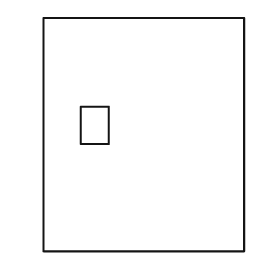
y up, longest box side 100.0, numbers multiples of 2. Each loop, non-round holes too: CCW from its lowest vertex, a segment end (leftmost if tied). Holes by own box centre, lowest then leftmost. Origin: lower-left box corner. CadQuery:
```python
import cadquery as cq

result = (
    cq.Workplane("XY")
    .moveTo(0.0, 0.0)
    .lineTo(86.0, 0.0)
    .lineTo(86.0, 100.0)
    .lineTo(0.0, 100.0)
    .close()
    .moveTo(16.0, 46.0)
    .lineTo(28.0, 46.0)
    .lineTo(28.0, 62.0)
    .lineTo(16.0, 62.0)
    .close()
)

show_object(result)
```